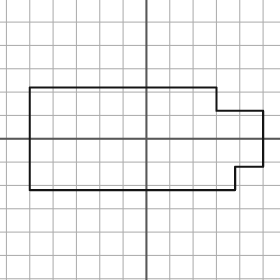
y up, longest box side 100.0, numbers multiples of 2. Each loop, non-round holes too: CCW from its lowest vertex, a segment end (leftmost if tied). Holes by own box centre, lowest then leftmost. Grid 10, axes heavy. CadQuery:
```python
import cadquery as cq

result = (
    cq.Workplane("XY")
    .moveTo(-50.0, -22.0)
    .lineTo(38.0, -22.0)
    .lineTo(38.0, -12.0)
    .lineTo(50.0, -12.0)
    .lineTo(50.0, 12.0)
    .lineTo(30.0, 12.0)
    .lineTo(30.0, 22.0)
    .lineTo(-50.0, 22.0)
    .close()
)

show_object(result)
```